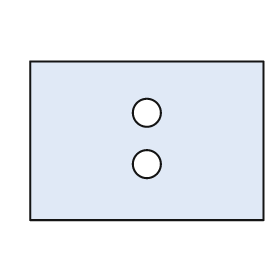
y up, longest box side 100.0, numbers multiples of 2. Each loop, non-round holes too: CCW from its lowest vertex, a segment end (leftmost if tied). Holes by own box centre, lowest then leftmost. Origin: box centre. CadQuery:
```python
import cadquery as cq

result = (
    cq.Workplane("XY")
    .moveTo(-50.0, -34.0)
    .lineTo(50.0, -34.0)
    .lineTo(50.0, 34.0)
    .lineTo(-50.0, 34.0)
    .close()
    .moveTo(0.0, -10.0)
    .circle(6.0)
    .moveTo(0.0, 12.0)
    .circle(6.0)
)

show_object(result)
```